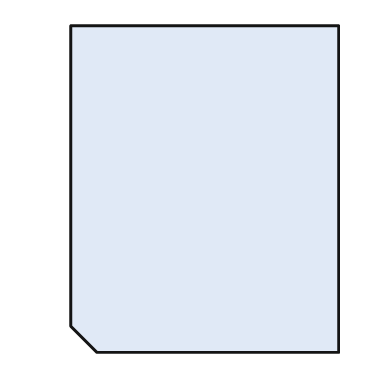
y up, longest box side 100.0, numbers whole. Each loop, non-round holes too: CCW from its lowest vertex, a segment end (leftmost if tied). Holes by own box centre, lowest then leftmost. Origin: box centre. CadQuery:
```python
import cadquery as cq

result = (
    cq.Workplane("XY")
    .moveTo(-33.0, -50.0)
    .lineTo(41.0, -50.0)
    .lineTo(41.0, 50.0)
    .lineTo(-41.0, 50.0)
    .lineTo(-41.0, -42.0)
    .close()
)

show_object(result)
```